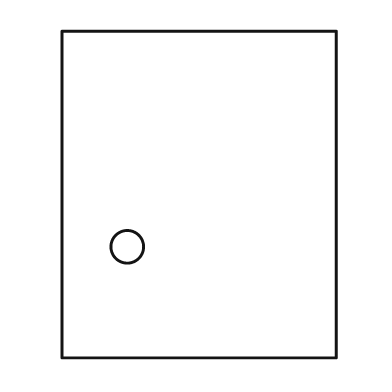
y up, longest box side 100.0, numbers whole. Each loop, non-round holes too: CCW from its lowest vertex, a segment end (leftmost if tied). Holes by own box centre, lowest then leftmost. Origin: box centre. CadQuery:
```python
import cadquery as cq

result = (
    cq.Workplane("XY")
    .moveTo(-42.0, -50.0)
    .lineTo(42.0, -50.0)
    .lineTo(42.0, 50.0)
    .lineTo(-42.0, 50.0)
    .close()
    .moveTo(-22.0, -16.0)
    .circle(5.0)
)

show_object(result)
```